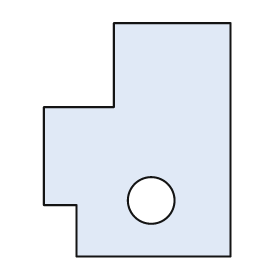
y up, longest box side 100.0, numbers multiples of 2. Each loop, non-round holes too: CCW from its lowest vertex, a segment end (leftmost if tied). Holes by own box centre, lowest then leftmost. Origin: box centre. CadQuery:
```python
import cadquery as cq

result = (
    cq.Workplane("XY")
    .moveTo(-26.0, -50.0)
    .lineTo(40.0, -50.0)
    .lineTo(40.0, 50.0)
    .lineTo(-10.0, 50.0)
    .lineTo(-10.0, 14.0)
    .lineTo(-40.0, 14.0)
    .lineTo(-40.0, -28.0)
    .lineTo(-26.0, -28.0)
    .close()
    .moveTo(6.0, -26.0)
    .circle(10.0)
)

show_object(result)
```